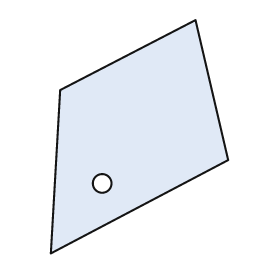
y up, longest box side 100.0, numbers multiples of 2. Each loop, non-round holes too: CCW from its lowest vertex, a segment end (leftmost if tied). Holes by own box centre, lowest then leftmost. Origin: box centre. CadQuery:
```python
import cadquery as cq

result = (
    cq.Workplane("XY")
    .moveTo(-38.0, -50.0)
    .lineTo(38.0, -10.0)
    .lineTo(24.0, 50.0)
    .lineTo(-34.0, 20.0)
    .close()
    .moveTo(-16.0, -20.0)
    .circle(4.0)
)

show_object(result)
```